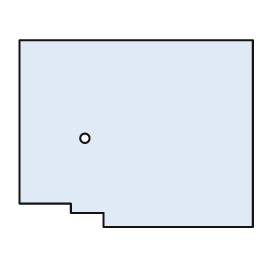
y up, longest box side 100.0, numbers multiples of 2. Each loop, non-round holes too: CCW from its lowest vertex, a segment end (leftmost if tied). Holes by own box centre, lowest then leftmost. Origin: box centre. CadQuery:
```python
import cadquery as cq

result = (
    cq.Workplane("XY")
    .moveTo(-14.0, -40.0)
    .lineTo(50.0, -40.0)
    .lineTo(50.0, 40.0)
    .lineTo(-50.0, 40.0)
    .lineTo(-50.0, -30.0)
    .lineTo(-28.0, -30.0)
    .lineTo(-28.0, -34.0)
    .lineTo(-14.0, -34.0)
    .close()
    .moveTo(-22.0, -2.0)
    .circle(2.0)
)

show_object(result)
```